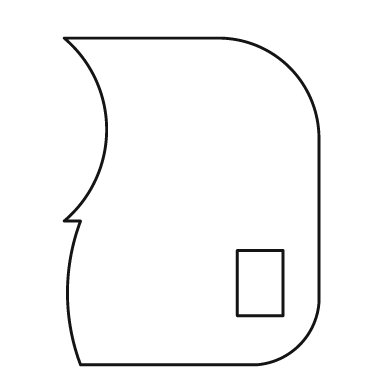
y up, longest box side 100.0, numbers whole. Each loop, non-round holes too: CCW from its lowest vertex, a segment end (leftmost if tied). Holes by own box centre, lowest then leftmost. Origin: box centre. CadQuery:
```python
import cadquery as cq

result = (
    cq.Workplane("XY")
    .moveTo(-34.0, -50.0)
    .lineTo(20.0, -50.0)
    .threePointArc((33.0, -44.0), (39.0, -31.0))
    .lineTo(39.0, 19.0)
    .threePointArc((30.0, 41.0), (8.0, 50.0))
    .lineTo(-39.0, 50.0)
    .threePointArc((-26.0, 22.0), (-39.0, -6.0))
    .lineTo(-34.0, -6.0)
    .threePointArc((-38.0, -28.0), (-34.0, -50.0))
    .close()
    .moveTo(14.0, -35.0)
    .lineTo(28.0, -35.0)
    .lineTo(28.0, -15.0)
    .lineTo(14.0, -15.0)
    .close()
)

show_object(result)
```